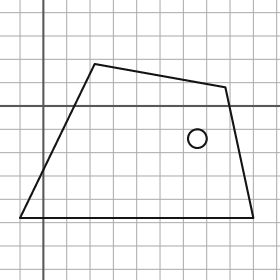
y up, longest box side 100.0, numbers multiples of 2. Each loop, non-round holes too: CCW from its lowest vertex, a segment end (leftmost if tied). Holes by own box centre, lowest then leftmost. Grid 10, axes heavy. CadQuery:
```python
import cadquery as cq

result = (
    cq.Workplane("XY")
    .moveTo(-10.0, -48.0)
    .lineTo(90.0, -48.0)
    .lineTo(78.0, 8.0)
    .lineTo(22.0, 18.0)
    .close()
    .moveTo(66.0, -14.0)
    .circle(4.0)
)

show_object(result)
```